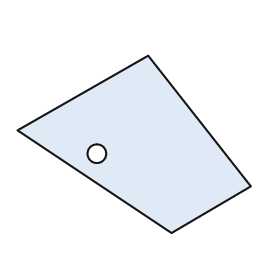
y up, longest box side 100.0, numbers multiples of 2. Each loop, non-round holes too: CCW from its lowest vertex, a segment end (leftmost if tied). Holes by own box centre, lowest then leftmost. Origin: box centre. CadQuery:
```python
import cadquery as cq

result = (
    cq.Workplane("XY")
    .moveTo(16.0, -38.0)
    .lineTo(50.0, -18.0)
    .lineTo(6.0, 38.0)
    .lineTo(-50.0, 6.0)
    .close()
    .moveTo(-16.0, -4.0)
    .circle(4.0)
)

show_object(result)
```